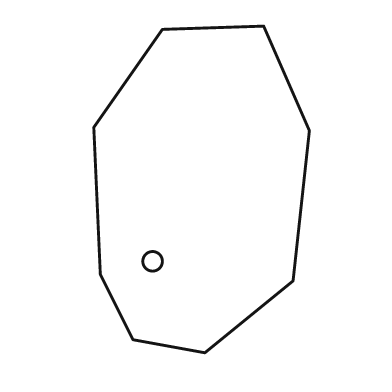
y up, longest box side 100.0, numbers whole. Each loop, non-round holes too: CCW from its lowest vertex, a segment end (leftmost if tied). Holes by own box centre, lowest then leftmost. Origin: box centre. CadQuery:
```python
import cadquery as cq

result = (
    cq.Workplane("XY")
    .moveTo(1.0, -50.0)
    .lineTo(28.0, -28.0)
    .lineTo(33.0, 18.0)
    .lineTo(19.0, 50.0)
    .lineTo(-12.0, 49.0)
    .lineTo(-33.0, 19.0)
    .lineTo(-31.0, -26.0)
    .lineTo(-21.0, -46.0)
    .close()
    .moveTo(-15.0, -22.0)
    .circle(3.0)
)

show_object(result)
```